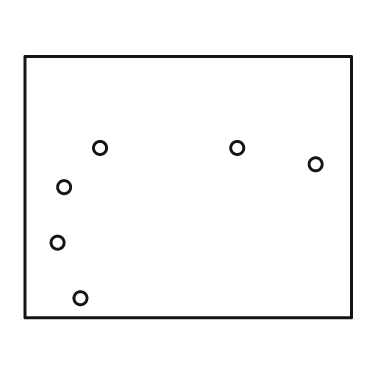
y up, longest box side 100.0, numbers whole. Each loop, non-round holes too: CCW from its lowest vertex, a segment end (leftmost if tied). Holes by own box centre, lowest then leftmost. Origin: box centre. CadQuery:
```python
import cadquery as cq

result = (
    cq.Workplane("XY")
    .moveTo(-50.0, -40.0)
    .lineTo(50.0, -40.0)
    .lineTo(50.0, 40.0)
    .lineTo(-50.0, 40.0)
    .close()
    .moveTo(-33.0, -34.0)
    .circle(2.0)
    .moveTo(-40.0, -17.0)
    .circle(2.0)
    .moveTo(-38.0, 0.0)
    .circle(2.0)
    .moveTo(39.0, 7.0)
    .circle(2.0)
    .moveTo(-27.0, 12.0)
    .circle(2.0)
    .moveTo(15.0, 12.0)
    .circle(2.0)
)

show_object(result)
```